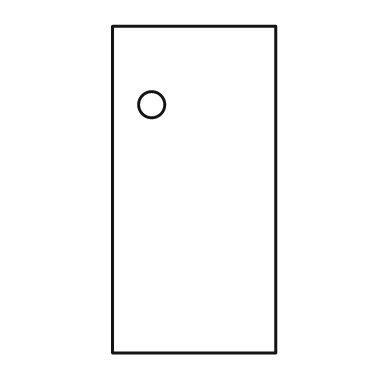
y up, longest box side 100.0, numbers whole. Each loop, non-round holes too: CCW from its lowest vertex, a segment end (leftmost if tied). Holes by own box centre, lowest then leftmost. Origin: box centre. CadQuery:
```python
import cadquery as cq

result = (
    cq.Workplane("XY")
    .moveTo(-25.0, -50.0)
    .lineTo(25.0, -50.0)
    .lineTo(25.0, 50.0)
    .lineTo(-25.0, 50.0)
    .close()
    .moveTo(-13.0, 26.0)
    .circle(4.0)
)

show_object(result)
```